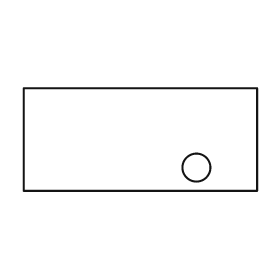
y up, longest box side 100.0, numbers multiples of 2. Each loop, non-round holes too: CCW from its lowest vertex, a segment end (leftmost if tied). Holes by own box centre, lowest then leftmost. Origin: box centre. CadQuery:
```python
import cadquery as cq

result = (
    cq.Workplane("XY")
    .moveTo(-50.0, -22.0)
    .lineTo(50.0, -22.0)
    .lineTo(50.0, 22.0)
    .lineTo(-50.0, 22.0)
    .close()
    .moveTo(24.0, -12.0)
    .circle(6.0)
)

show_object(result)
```